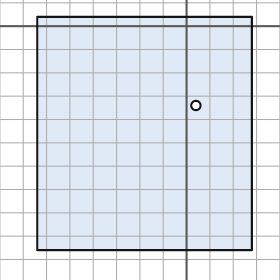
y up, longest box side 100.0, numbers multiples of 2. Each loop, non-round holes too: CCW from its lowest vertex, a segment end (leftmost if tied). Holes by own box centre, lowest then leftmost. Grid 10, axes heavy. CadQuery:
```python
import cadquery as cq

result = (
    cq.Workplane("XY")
    .moveTo(-64.0, -96.0)
    .lineTo(28.0, -96.0)
    .lineTo(28.0, 4.0)
    .lineTo(-64.0, 4.0)
    .close()
    .moveTo(4.0, -34.0)
    .circle(2.0)
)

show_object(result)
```